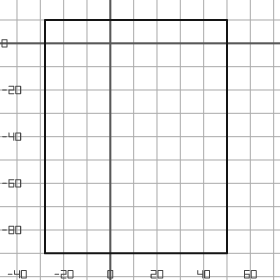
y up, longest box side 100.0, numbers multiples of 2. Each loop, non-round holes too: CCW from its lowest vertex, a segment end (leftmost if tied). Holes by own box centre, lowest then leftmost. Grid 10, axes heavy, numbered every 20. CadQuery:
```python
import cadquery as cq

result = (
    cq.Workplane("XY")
    .moveTo(-28.0, -90.0)
    .lineTo(50.0, -90.0)
    .lineTo(50.0, 10.0)
    .lineTo(-28.0, 10.0)
    .close()
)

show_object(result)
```